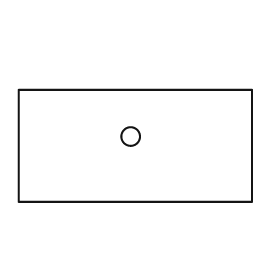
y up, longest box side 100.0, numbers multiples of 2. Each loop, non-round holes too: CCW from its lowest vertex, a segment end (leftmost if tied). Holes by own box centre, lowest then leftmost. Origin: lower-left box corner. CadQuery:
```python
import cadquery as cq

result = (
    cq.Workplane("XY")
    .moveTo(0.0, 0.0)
    .lineTo(100.0, 0.0)
    .lineTo(100.0, 48.0)
    .lineTo(0.0, 48.0)
    .close()
    .moveTo(48.0, 28.0)
    .circle(4.0)
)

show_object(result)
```